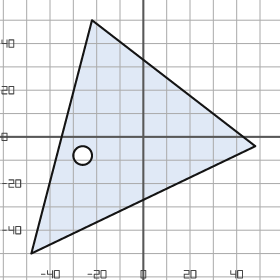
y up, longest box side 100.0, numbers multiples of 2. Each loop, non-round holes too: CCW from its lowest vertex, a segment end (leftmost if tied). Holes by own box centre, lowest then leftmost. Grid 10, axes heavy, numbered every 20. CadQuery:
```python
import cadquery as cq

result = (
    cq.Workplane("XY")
    .moveTo(-48.0, -50.0)
    .lineTo(48.0, -4.0)
    .lineTo(-22.0, 50.0)
    .close()
    .moveTo(-26.0, -8.0)
    .circle(4.0)
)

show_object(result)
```